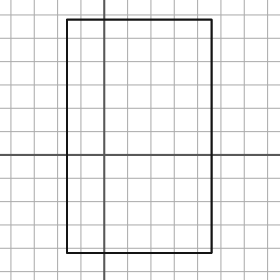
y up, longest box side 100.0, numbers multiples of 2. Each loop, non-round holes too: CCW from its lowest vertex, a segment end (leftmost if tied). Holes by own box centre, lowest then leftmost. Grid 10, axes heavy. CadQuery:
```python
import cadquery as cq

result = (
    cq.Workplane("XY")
    .moveTo(-16.0, -42.0)
    .lineTo(46.0, -42.0)
    .lineTo(46.0, 58.0)
    .lineTo(-16.0, 58.0)
    .close()
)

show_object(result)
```